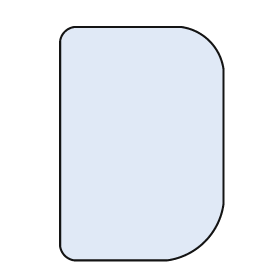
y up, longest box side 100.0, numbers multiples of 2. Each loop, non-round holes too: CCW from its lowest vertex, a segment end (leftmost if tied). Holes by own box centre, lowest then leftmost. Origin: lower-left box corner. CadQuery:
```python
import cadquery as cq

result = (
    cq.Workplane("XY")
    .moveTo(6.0, 0.0)
    .lineTo(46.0, 0.0)
    .threePointArc((62.0, 8.0), (70.0, 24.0))
    .lineTo(70.0, 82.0)
    .threePointArc((64.0, 94.0), (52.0, 100.0))
    .lineTo(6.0, 100.0)
    .threePointArc((2.0, 98.0), (0.0, 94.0))
    .lineTo(0.0, 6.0)
    .threePointArc((2.0, 2.0), (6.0, 0.0))
    .close()
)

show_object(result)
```